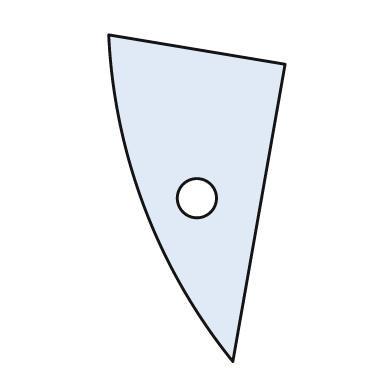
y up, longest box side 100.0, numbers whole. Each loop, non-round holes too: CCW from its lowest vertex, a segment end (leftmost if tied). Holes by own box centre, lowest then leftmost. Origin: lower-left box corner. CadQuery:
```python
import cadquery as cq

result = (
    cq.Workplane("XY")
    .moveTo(38.0, 0.0)
    .lineTo(54.0, 91.0)
    .lineTo(0.0, 100.0)
    .threePointArc((11.0, 47.0), (38.0, 0.0))
    .close()
    .moveTo(27.0, 50.0)
    .circle(6.0)
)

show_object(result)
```